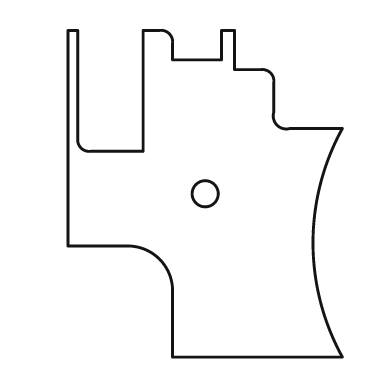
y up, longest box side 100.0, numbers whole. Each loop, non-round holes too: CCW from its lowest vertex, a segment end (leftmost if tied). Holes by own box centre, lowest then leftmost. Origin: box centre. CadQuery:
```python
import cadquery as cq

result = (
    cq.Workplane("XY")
    .moveTo(-10.0, -50.0)
    .lineTo(42.0, -50.0)
    .threePointArc((33.0, -15.0), (42.0, 20.0))
    .lineTo(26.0, 20.0)
    .threePointArc((22.0, 21.0), (21.0, 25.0))
    .lineTo(21.0, 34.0)
    .threePointArc((20.0, 37.0), (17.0, 38.0))
    .lineTo(9.0, 38.0)
    .lineTo(9.0, 50.0)
    .lineTo(5.0, 50.0)
    .lineTo(5.0, 41.0)
    .lineTo(-10.0, 41.0)
    .lineTo(-10.0, 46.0)
    .threePointArc((-11.0, 49.0), (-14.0, 50.0))
    .lineTo(-19.0, 50.0)
    .lineTo(-19.0, 13.0)
    .lineTo(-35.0, 13.0)
    .threePointArc((-38.0, 14.0), (-39.0, 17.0))
    .lineTo(-39.0, 50.0)
    .lineTo(-42.0, 50.0)
    .lineTo(-42.0, -16.0)
    .lineTo(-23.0, -16.0)
    .threePointArc((-14.0, -20.0), (-10.0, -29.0))
    .close()
    .moveTo(0.0, 0.0)
    .circle(4.0)
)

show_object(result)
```